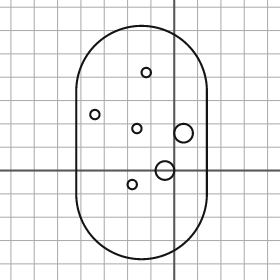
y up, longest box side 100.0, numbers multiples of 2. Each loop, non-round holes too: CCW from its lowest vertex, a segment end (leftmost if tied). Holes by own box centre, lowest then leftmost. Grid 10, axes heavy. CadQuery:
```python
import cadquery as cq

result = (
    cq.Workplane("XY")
    .moveTo(-42.0, -10.0)
    .threePointArc((-14.0, -38.0), (14.0, -10.0))
    .lineTo(14.0, 34.0)
    .threePointArc((-14.0, 62.0), (-42.0, 34.0))
    .close()
    .moveTo(-18.0, -6.0)
    .circle(2.0)
    .moveTo(-4.0, 0.0)
    .circle(4.0)
    .moveTo(4.0, 16.0)
    .circle(4.0)
    .moveTo(-16.0, 18.0)
    .circle(2.0)
    .moveTo(-34.0, 24.0)
    .circle(2.0)
    .moveTo(-12.0, 42.0)
    .circle(2.0)
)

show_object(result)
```